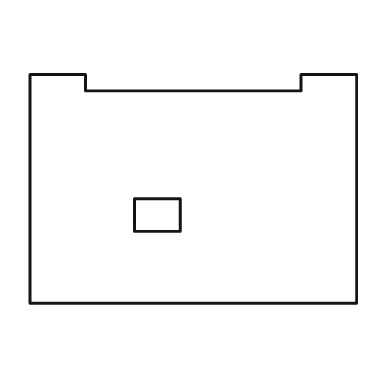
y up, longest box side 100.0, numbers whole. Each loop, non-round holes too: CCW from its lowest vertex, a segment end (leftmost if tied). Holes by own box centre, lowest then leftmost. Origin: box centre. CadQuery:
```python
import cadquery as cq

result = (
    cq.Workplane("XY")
    .moveTo(-50.0, -35.0)
    .lineTo(50.0, -35.0)
    .lineTo(50.0, 35.0)
    .lineTo(33.0, 35.0)
    .lineTo(33.0, 30.0)
    .lineTo(-33.0, 30.0)
    .lineTo(-33.0, 35.0)
    .lineTo(-50.0, 35.0)
    .close()
    .moveTo(-18.0, -13.0)
    .lineTo(-4.0, -13.0)
    .lineTo(-4.0, -3.0)
    .lineTo(-18.0, -3.0)
    .close()
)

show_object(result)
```